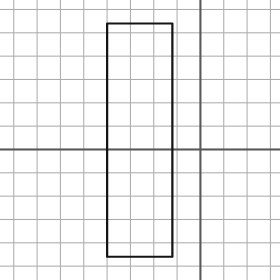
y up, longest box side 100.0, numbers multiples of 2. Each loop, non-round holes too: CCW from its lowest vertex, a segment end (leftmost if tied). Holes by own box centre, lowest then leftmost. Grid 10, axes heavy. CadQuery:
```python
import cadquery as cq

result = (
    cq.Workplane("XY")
    .moveTo(-40.0, -46.0)
    .lineTo(-12.0, -46.0)
    .lineTo(-12.0, 54.0)
    .lineTo(-40.0, 54.0)
    .close()
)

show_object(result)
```